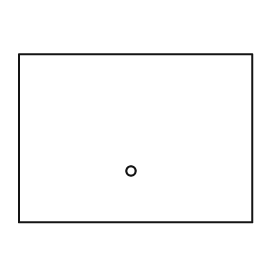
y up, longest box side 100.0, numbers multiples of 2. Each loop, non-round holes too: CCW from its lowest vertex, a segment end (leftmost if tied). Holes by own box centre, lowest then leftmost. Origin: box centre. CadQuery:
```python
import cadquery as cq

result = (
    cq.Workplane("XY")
    .moveTo(-50.0, -36.0)
    .lineTo(50.0, -36.0)
    .lineTo(50.0, 36.0)
    .lineTo(-50.0, 36.0)
    .close()
    .moveTo(-2.0, -14.0)
    .circle(2.0)
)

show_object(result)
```